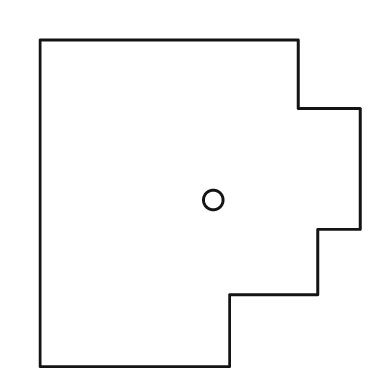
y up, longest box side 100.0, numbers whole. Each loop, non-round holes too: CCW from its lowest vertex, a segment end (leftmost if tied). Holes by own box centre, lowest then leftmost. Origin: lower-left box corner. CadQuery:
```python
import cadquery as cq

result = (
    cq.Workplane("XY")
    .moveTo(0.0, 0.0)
    .lineTo(58.0, 0.0)
    .lineTo(58.0, 22.0)
    .lineTo(85.0, 22.0)
    .lineTo(85.0, 42.0)
    .lineTo(98.0, 42.0)
    .lineTo(98.0, 79.0)
    .lineTo(79.0, 79.0)
    .lineTo(79.0, 100.0)
    .lineTo(0.0, 100.0)
    .close()
    .moveTo(53.0, 51.0)
    .circle(3.0)
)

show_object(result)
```